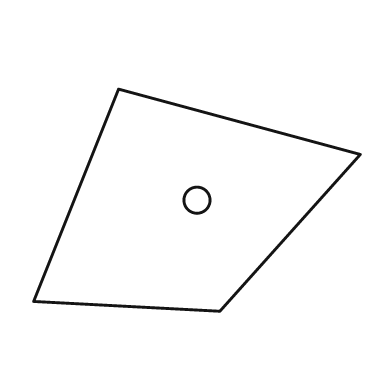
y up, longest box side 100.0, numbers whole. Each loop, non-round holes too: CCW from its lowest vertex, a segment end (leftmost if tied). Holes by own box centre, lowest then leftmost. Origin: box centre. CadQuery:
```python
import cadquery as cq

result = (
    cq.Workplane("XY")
    .moveTo(7.0, -34.0)
    .lineTo(50.0, 14.0)
    .lineTo(-24.0, 34.0)
    .lineTo(-50.0, -31.0)
    .close()
    .moveTo(0.0, 0.0)
    .circle(4.0)
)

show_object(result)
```